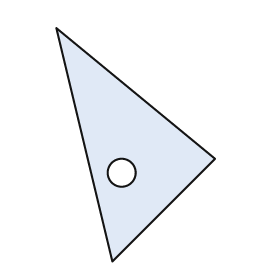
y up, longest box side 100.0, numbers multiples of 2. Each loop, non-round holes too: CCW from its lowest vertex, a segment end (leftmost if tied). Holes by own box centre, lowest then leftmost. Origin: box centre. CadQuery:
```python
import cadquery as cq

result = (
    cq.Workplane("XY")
    .moveTo(-10.0, -50.0)
    .lineTo(34.0, -6.0)
    .lineTo(-34.0, 50.0)
    .close()
    .moveTo(-6.0, -12.0)
    .circle(6.0)
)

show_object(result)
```